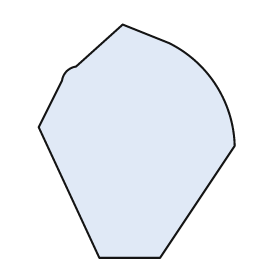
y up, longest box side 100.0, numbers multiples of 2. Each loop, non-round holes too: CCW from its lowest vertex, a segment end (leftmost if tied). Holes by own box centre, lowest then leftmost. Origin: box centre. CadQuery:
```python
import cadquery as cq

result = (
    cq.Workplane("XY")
    .moveTo(-16.0, -50.0)
    .lineTo(10.0, -50.0)
    .lineTo(42.0, -2.0)
    .threePointArc((34.0, 24.0), (14.0, 42.0))
    .lineTo(-6.0, 50.0)
    .lineTo(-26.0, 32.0)
    .threePointArc((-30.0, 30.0), (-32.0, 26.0))
    .lineTo(-42.0, 6.0)
    .close()
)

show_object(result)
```